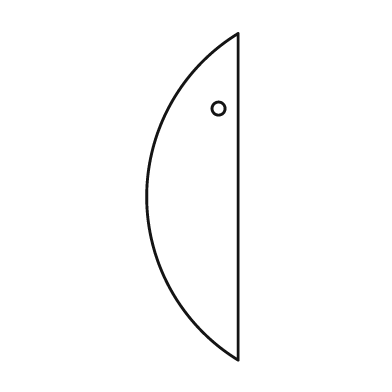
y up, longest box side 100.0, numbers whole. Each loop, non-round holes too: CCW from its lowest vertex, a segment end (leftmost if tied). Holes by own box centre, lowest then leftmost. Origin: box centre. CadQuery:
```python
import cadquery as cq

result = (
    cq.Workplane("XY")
    .moveTo(14.0, -50.0)
    .lineTo(14.0, 50.0)
    .threePointArc((-14.0, 0.0), (14.0, -50.0))
    .close()
    .moveTo(8.0, 27.0)
    .circle(2.0)
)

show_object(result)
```